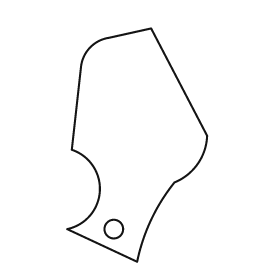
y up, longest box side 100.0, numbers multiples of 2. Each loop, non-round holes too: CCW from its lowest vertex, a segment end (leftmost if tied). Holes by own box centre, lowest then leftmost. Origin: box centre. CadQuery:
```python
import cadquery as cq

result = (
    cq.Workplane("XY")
    .moveTo(0.0, -50.0)
    .threePointArc((6.0, -32.0), (16.0, -16.0))
    .threePointArc((26.0, -8.0), (30.0, 4.0))
    .lineTo(6.0, 50.0)
    .lineTo(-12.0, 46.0)
    .threePointArc((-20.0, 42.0), (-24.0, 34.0))
    .lineTo(-28.0, -2.0)
    .threePointArc((-16.0, -20.0), (-30.0, -36.0))
    .close()
    .moveTo(-10.0, -36.0)
    .circle(4.0)
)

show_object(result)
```